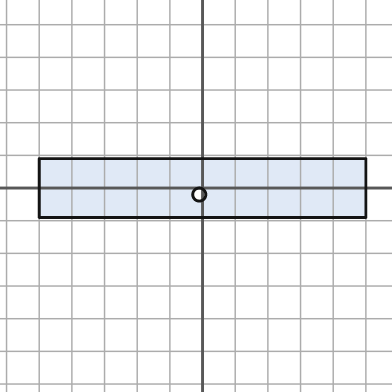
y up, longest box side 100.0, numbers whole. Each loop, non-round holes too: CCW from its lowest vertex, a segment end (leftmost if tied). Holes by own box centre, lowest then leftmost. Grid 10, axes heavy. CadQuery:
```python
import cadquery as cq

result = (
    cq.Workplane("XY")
    .moveTo(-50.0, -9.0)
    .lineTo(50.0, -9.0)
    .lineTo(50.0, 9.0)
    .lineTo(-50.0, 9.0)
    .close()
    .moveTo(-1.0, -2.0)
    .circle(2.0)
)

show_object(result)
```